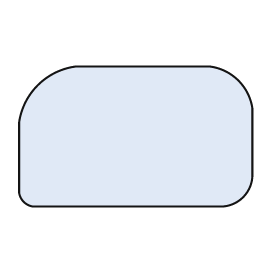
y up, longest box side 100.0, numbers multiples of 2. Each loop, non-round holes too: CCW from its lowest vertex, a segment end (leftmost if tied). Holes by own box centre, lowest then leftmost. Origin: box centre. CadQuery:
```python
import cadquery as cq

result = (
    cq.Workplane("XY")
    .moveTo(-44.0, -30.0)
    .lineTo(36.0, -30.0)
    .threePointArc((46.0, -26.0), (50.0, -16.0))
    .lineTo(50.0, 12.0)
    .threePointArc((44.0, 24.0), (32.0, 30.0))
    .lineTo(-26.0, 30.0)
    .threePointArc((-42.0, 22.0), (-50.0, 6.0))
    .lineTo(-50.0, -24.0)
    .threePointArc((-48.0, -28.0), (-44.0, -30.0))
    .close()
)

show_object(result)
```